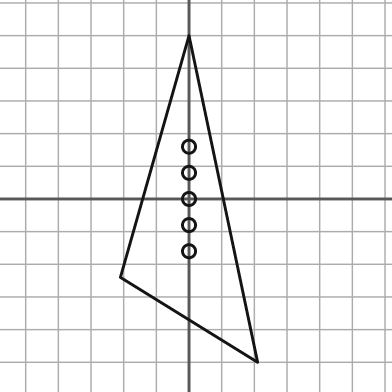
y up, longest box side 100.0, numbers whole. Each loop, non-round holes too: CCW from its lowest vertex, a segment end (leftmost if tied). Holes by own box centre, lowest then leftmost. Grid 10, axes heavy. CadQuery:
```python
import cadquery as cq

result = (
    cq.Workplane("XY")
    .moveTo(21.0, -50.0)
    .lineTo(0.0, 50.0)
    .lineTo(-21.0, -24.0)
    .close()
    .moveTo(0.0, -16.0)
    .circle(2.0)
    .moveTo(0.0, -8.0)
    .circle(2.0)
    .moveTo(0.0, 0.0)
    .circle(2.0)
    .moveTo(0.0, 8.0)
    .circle(2.0)
    .moveTo(0.0, 16.0)
    .circle(2.0)
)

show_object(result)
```